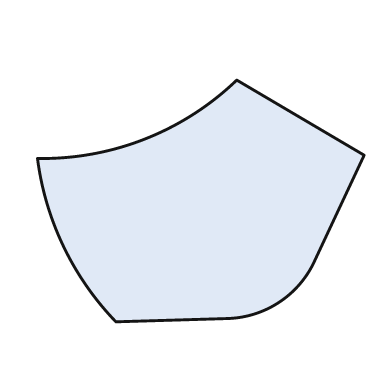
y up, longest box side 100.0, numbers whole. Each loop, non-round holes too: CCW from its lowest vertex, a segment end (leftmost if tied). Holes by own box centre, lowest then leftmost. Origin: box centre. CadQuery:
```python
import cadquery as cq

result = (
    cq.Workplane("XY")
    .moveTo(-26.0, -37.0)
    .lineTo(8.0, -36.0)
    .threePointArc((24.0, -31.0), (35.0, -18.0))
    .lineTo(50.0, 14.0)
    .lineTo(11.0, 37.0)
    .threePointArc((-17.0, 19.0), (-50.0, 13.0))
    .threePointArc((-42.0, -14.0), (-26.0, -37.0))
    .close()
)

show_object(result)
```